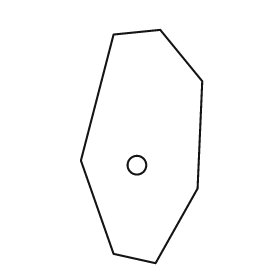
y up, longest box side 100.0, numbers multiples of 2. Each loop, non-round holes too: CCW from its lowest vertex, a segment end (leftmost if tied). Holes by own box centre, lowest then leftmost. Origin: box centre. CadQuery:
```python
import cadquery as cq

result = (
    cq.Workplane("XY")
    .moveTo(6.0, -50.0)
    .lineTo(24.0, -18.0)
    .lineTo(26.0, 28.0)
    .lineTo(8.0, 50.0)
    .lineTo(-12.0, 48.0)
    .lineTo(-26.0, -6.0)
    .lineTo(-12.0, -46.0)
    .close()
    .moveTo(-2.0, -8.0)
    .circle(4.0)
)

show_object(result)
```